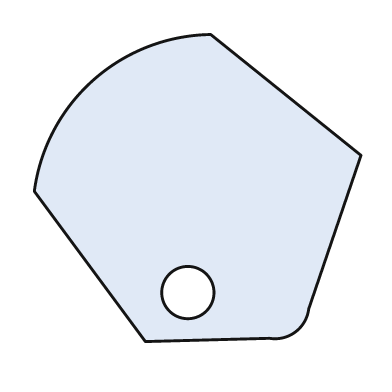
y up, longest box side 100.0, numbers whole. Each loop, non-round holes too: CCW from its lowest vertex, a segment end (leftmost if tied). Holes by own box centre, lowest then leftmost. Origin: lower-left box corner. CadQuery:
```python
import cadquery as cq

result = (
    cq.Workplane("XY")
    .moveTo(34.0, 0.0)
    .lineTo(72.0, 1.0)
    .threePointArc((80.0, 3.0), (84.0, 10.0))
    .lineTo(100.0, 57.0)
    .lineTo(54.0, 94.0)
    .threePointArc((18.0, 80.0), (0.0, 46.0))
    .close()
    .moveTo(47.0, 15.0)
    .circle(8.0)
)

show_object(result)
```